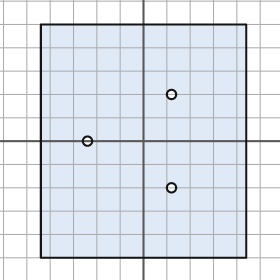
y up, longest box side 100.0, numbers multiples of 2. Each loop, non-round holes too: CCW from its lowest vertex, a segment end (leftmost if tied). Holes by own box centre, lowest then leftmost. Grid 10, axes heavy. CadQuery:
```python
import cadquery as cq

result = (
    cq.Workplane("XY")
    .moveTo(-44.0, -50.0)
    .lineTo(44.0, -50.0)
    .lineTo(44.0, 50.0)
    .lineTo(-44.0, 50.0)
    .close()
    .moveTo(12.0, -20.0)
    .circle(2.0)
    .moveTo(-24.0, 0.0)
    .circle(2.0)
    .moveTo(12.0, 20.0)
    .circle(2.0)
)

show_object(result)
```